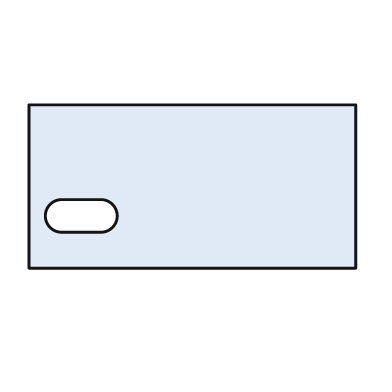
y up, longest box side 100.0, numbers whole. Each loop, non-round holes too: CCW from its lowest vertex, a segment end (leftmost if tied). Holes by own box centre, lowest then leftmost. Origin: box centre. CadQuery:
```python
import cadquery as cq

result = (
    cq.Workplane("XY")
    .moveTo(-50.0, -25.0)
    .lineTo(50.0, -25.0)
    .lineTo(50.0, 25.0)
    .lineTo(-50.0, 25.0)
    .close()
    .moveTo(-40.0, -14.0)
    .lineTo(-28.0, -14.0)
    .threePointArc((-23.0, -9.0), (-28.0, -4.0))
    .lineTo(-40.0, -4.0)
    .threePointArc((-45.0, -9.0), (-40.0, -14.0))
    .close()
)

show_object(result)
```